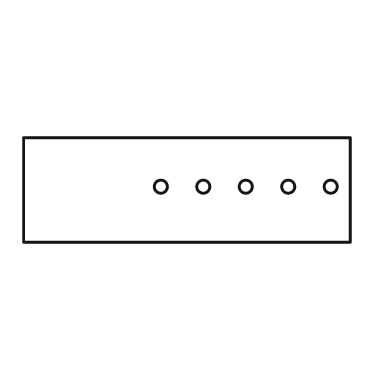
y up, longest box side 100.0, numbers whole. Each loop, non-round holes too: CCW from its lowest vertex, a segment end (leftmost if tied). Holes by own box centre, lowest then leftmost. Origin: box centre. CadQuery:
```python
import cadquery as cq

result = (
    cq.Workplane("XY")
    .moveTo(-50.0, -16.0)
    .lineTo(50.0, -16.0)
    .lineTo(50.0, 16.0)
    .lineTo(-50.0, 16.0)
    .close()
    .moveTo(-8.0, 1.0)
    .circle(2.0)
    .moveTo(5.0, 1.0)
    .circle(2.0)
    .moveTo(18.0, 1.0)
    .circle(2.0)
    .moveTo(31.0, 1.0)
    .circle(2.0)
    .moveTo(44.0, 1.0)
    .circle(2.0)
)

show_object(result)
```